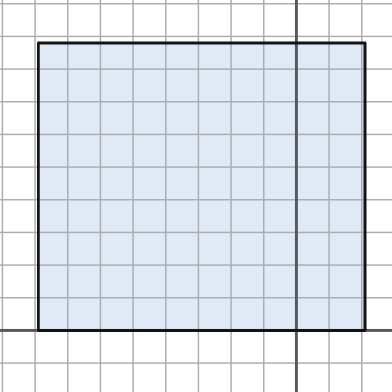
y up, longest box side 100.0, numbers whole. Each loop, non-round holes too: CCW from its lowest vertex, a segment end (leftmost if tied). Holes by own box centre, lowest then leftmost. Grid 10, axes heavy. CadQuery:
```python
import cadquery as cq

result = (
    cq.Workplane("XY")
    .moveTo(-79.0, 0.0)
    .lineTo(21.0, 0.0)
    .lineTo(21.0, 88.0)
    .lineTo(-79.0, 88.0)
    .close()
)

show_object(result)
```